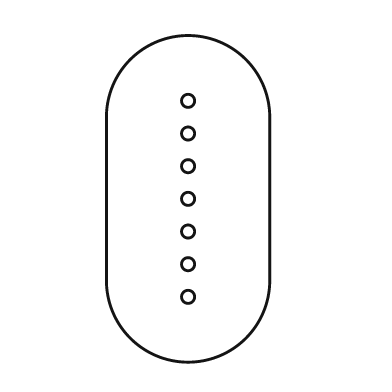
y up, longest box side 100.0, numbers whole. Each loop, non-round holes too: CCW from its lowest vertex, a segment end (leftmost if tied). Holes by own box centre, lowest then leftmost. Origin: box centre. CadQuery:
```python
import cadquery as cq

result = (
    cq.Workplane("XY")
    .moveTo(-25.0, -25.0)
    .threePointArc((0.0, -50.0), (25.0, -25.0))
    .lineTo(25.0, 25.0)
    .threePointArc((0.0, 50.0), (-25.0, 25.0))
    .close()
    .moveTo(0.0, -30.0)
    .circle(2.0)
    .moveTo(0.0, -20.0)
    .circle(2.0)
    .moveTo(0.0, -10.0)
    .circle(2.0)
    .moveTo(0.0, 0.0)
    .circle(2.0)
    .moveTo(0.0, 10.0)
    .circle(2.0)
    .moveTo(0.0, 20.0)
    .circle(2.0)
    .moveTo(0.0, 30.0)
    .circle(2.0)
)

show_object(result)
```